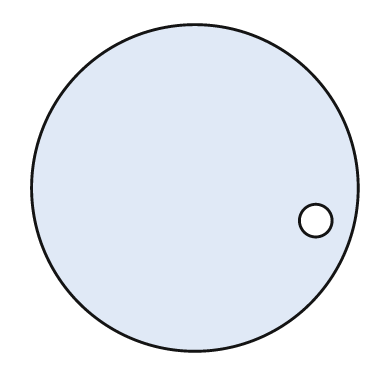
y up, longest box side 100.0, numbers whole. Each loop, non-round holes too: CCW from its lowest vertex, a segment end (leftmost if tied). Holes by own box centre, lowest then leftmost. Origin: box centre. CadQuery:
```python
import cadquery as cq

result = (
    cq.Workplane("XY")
    .moveTo(0.0, 0.0)
    .circle(50.0)
    .moveTo(37.0, -10.0)
    .circle(5.0)
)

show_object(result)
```